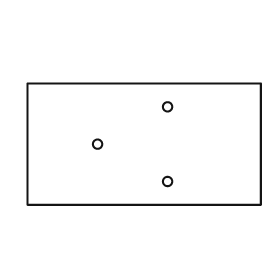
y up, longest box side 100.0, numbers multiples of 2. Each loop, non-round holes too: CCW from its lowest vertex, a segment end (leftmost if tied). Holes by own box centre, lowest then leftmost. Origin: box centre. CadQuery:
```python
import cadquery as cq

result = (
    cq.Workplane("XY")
    .moveTo(-50.0, -26.0)
    .lineTo(50.0, -26.0)
    .lineTo(50.0, 26.0)
    .lineTo(-50.0, 26.0)
    .close()
    .moveTo(10.0, -16.0)
    .circle(2.0)
    .moveTo(-20.0, 0.0)
    .circle(2.0)
    .moveTo(10.0, 16.0)
    .circle(2.0)
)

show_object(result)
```